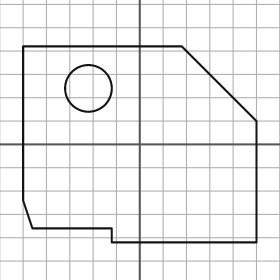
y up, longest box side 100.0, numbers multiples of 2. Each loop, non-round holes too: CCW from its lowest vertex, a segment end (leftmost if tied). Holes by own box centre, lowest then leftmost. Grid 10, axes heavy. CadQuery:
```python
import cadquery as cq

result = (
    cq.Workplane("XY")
    .moveTo(-12.0, -42.0)
    .lineTo(50.0, -42.0)
    .lineTo(50.0, 10.0)
    .lineTo(18.0, 42.0)
    .lineTo(-50.0, 42.0)
    .lineTo(-50.0, -24.0)
    .lineTo(-46.0, -36.0)
    .lineTo(-12.0, -36.0)
    .close()
    .moveTo(-22.0, 24.0)
    .circle(10.0)
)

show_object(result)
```